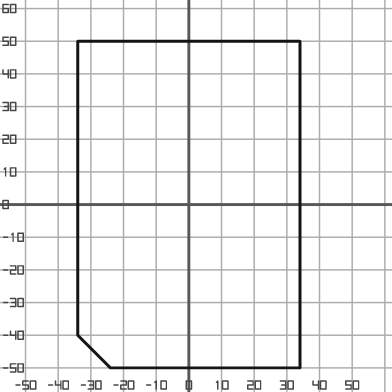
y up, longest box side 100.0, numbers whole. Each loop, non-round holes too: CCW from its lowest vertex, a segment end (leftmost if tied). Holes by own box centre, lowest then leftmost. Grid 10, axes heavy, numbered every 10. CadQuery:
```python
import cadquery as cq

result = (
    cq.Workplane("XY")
    .moveTo(-24.0, -50.0)
    .lineTo(34.0, -50.0)
    .lineTo(34.0, 50.0)
    .lineTo(-34.0, 50.0)
    .lineTo(-34.0, -40.0)
    .close()
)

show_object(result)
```